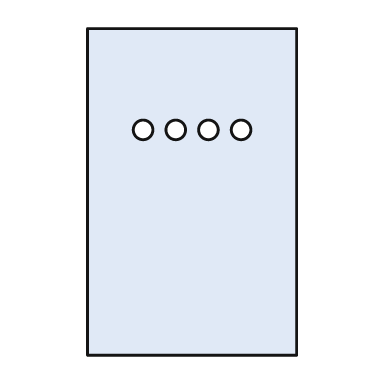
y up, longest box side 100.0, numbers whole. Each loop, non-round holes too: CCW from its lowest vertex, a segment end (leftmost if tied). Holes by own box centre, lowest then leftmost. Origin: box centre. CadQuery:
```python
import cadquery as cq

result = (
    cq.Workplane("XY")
    .moveTo(-32.0, -50.0)
    .lineTo(32.0, -50.0)
    .lineTo(32.0, 50.0)
    .lineTo(-32.0, 50.0)
    .close()
    .moveTo(-15.0, 19.0)
    .circle(3.0)
    .moveTo(-5.0, 19.0)
    .circle(3.0)
    .moveTo(5.0, 19.0)
    .circle(3.0)
    .moveTo(15.0, 19.0)
    .circle(3.0)
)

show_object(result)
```